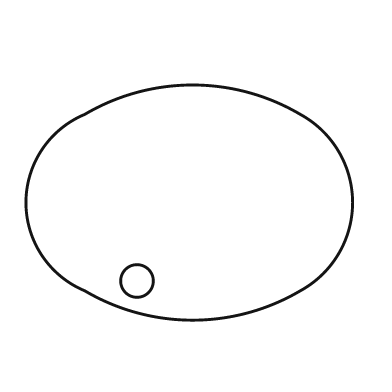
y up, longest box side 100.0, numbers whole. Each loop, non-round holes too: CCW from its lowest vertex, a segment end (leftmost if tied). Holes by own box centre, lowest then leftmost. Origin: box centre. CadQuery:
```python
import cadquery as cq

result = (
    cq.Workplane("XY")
    .moveTo(-32.0, -27.0)
    .threePointArc((1.0, -36.0), (34.0, -27.0))
    .threePointArc((50.0, 0.0), (34.0, 27.0))
    .threePointArc((1.0, 36.0), (-32.0, 27.0))
    .threePointArc((-50.0, 0.0), (-32.0, -27.0))
    .close()
    .moveTo(-16.0, -24.0)
    .circle(5.0)
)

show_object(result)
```